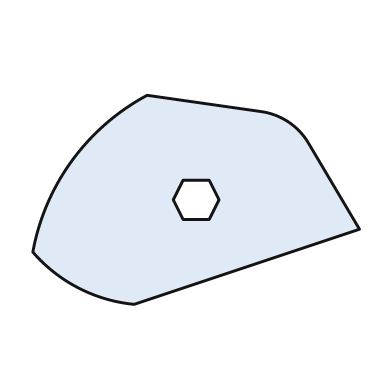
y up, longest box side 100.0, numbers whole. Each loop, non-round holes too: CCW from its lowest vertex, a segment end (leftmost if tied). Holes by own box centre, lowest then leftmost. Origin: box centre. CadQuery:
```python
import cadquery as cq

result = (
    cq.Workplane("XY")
    .moveTo(-19.0, -32.0)
    .lineTo(50.0, -9.0)
    .lineTo(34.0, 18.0)
    .threePointArc((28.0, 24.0), (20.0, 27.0))
    .lineTo(-15.0, 32.0)
    .threePointArc((-38.0, 12.0), (-50.0, -16.0))
    .threePointArc((-36.0, -27.0), (-19.0, -32.0))
    .close()
    .moveTo(-4.0, -6.0)
    .lineTo(4.0, -6.0)
    .lineTo(7.0, 0.0)
    .lineTo(4.0, 6.0)
    .lineTo(-4.0, 6.0)
    .lineTo(-7.0, 0.0)
    .close()
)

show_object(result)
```